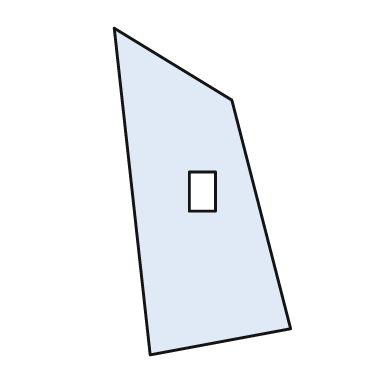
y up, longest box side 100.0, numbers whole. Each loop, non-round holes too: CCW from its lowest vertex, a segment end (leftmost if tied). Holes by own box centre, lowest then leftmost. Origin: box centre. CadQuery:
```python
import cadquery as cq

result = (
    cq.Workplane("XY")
    .moveTo(-16.0, -50.0)
    .lineTo(27.0, -42.0)
    .lineTo(9.0, 28.0)
    .lineTo(-27.0, 50.0)
    .close()
    .moveTo(-4.0, -6.0)
    .lineTo(4.0, -6.0)
    .lineTo(4.0, 6.0)
    .lineTo(-4.0, 6.0)
    .close()
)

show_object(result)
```